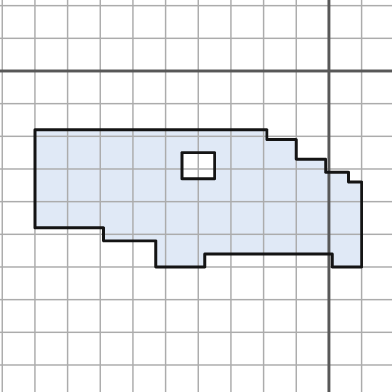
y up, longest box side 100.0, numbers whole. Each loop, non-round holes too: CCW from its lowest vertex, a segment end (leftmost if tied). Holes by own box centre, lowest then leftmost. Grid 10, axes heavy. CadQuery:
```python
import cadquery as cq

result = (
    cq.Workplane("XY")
    .moveTo(-53.0, -60.0)
    .lineTo(-38.0, -60.0)
    .lineTo(-38.0, -56.0)
    .lineTo(1.0, -56.0)
    .lineTo(1.0, -60.0)
    .lineTo(10.0, -60.0)
    .lineTo(10.0, -34.0)
    .lineTo(6.0, -34.0)
    .lineTo(6.0, -31.0)
    .lineTo(-1.0, -31.0)
    .lineTo(-1.0, -27.0)
    .lineTo(-10.0, -27.0)
    .lineTo(-10.0, -21.0)
    .lineTo(-19.0, -21.0)
    .lineTo(-19.0, -18.0)
    .lineTo(-90.0, -18.0)
    .lineTo(-90.0, -48.0)
    .lineTo(-69.0, -48.0)
    .lineTo(-69.0, -52.0)
    .lineTo(-53.0, -52.0)
    .close()
    .moveTo(-45.0, -33.0)
    .lineTo(-35.0, -33.0)
    .lineTo(-35.0, -25.0)
    .lineTo(-45.0, -25.0)
    .close()
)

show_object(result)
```